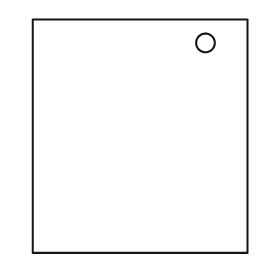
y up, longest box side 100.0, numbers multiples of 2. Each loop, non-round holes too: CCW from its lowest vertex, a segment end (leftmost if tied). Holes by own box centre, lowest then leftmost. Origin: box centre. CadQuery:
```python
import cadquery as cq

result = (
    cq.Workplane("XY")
    .moveTo(-46.0, -50.0)
    .lineTo(46.0, -50.0)
    .lineTo(46.0, 50.0)
    .lineTo(-46.0, 50.0)
    .close()
    .moveTo(28.0, 40.0)
    .circle(4.0)
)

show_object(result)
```